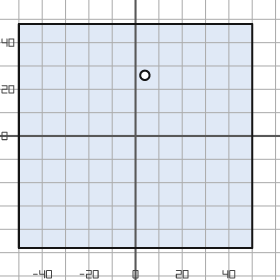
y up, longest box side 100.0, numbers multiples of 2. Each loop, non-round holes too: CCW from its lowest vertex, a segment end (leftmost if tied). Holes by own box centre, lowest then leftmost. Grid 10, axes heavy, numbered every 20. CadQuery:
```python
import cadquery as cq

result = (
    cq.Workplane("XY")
    .moveTo(-50.0, -48.0)
    .lineTo(50.0, -48.0)
    .lineTo(50.0, 48.0)
    .lineTo(-50.0, 48.0)
    .close()
    .moveTo(4.0, 26.0)
    .circle(2.0)
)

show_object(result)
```